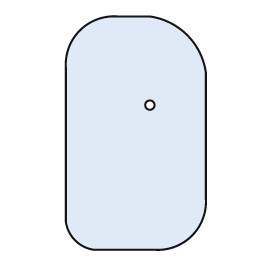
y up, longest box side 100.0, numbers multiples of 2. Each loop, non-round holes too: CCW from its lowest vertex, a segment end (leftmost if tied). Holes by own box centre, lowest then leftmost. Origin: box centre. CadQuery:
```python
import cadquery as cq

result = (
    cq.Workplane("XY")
    .moveTo(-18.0, -50.0)
    .lineTo(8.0, -50.0)
    .threePointArc((24.0, -44.0), (30.0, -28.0))
    .lineTo(30.0, 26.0)
    .threePointArc((22.0, 42.0), (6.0, 50.0))
    .lineTo(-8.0, 50.0)
    .threePointArc((-24.0, 44.0), (-30.0, 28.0))
    .lineTo(-30.0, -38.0)
    .threePointArc((-26.0, -46.0), (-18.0, -50.0))
    .close()
    .moveTo(6.0, 12.0)
    .circle(2.0)
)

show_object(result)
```